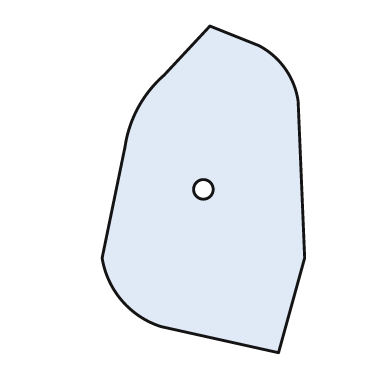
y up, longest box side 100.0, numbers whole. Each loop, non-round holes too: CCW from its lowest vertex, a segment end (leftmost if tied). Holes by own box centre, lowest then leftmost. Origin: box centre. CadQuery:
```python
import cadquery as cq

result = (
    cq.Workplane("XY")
    .moveTo(23.0, -50.0)
    .lineTo(31.0, -21.0)
    .lineTo(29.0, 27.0)
    .threePointArc((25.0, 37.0), (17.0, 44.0))
    .lineTo(2.0, 50.0)
    .lineTo(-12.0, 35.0)
    .threePointArc((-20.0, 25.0), (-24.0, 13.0))
    .lineTo(-31.0, -21.0)
    .threePointArc((-25.0, -34.0), (-13.0, -42.0))
    .close()
    .moveTo(0.0, 0.0)
    .circle(3.0)
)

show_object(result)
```